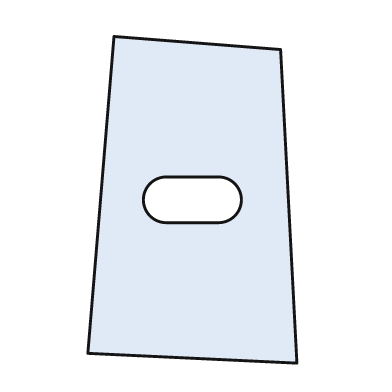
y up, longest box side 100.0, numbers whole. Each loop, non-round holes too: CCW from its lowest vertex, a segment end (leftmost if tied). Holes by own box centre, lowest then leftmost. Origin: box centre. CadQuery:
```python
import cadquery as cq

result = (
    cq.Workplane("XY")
    .moveTo(32.0, -50.0)
    .lineTo(27.0, 46.0)
    .lineTo(-24.0, 50.0)
    .lineTo(-32.0, -47.0)
    .close()
    .moveTo(-8.0, -7.0)
    .lineTo(8.0, -7.0)
    .threePointArc((15.0, 0.0), (8.0, 7.0))
    .lineTo(-8.0, 7.0)
    .threePointArc((-15.0, 0.0), (-8.0, -7.0))
    .close()
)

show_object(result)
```